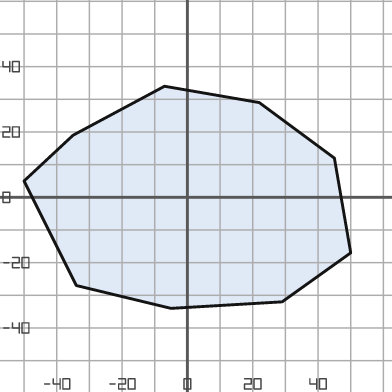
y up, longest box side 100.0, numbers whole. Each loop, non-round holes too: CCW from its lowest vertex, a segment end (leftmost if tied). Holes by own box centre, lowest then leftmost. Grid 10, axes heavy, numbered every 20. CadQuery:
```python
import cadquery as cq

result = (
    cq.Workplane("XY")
    .moveTo(-5.0, -34.0)
    .lineTo(29.0, -32.0)
    .lineTo(50.0, -17.0)
    .lineTo(45.0, 12.0)
    .lineTo(22.0, 29.0)
    .lineTo(-7.0, 34.0)
    .lineTo(-35.0, 19.0)
    .lineTo(-50.0, 5.0)
    .lineTo(-34.0, -27.0)
    .close()
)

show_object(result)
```